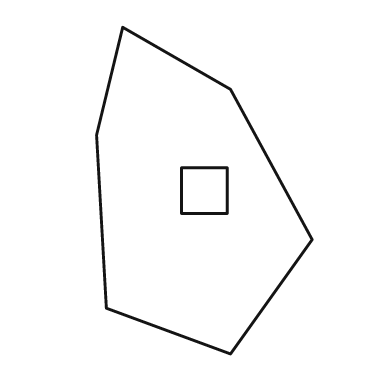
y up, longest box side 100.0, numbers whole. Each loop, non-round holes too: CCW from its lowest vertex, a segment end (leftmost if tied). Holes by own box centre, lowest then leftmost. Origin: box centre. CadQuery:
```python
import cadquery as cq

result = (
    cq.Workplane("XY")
    .moveTo(8.0, -50.0)
    .lineTo(33.0, -15.0)
    .lineTo(8.0, 31.0)
    .lineTo(-25.0, 50.0)
    .lineTo(-33.0, 17.0)
    .lineTo(-30.0, -36.0)
    .close()
    .moveTo(-7.0, -7.0)
    .lineTo(7.0, -7.0)
    .lineTo(7.0, 7.0)
    .lineTo(-7.0, 7.0)
    .close()
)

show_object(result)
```